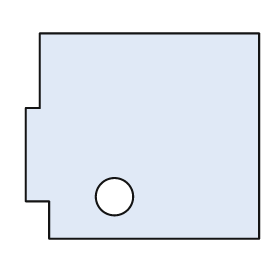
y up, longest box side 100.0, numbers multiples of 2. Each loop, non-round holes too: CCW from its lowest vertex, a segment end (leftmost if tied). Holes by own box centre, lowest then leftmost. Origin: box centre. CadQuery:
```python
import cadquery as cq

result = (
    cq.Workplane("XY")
    .moveTo(-40.0, -44.0)
    .lineTo(50.0, -44.0)
    .lineTo(50.0, 44.0)
    .lineTo(-44.0, 44.0)
    .lineTo(-44.0, 12.0)
    .lineTo(-50.0, 12.0)
    .lineTo(-50.0, -28.0)
    .lineTo(-40.0, -28.0)
    .close()
    .moveTo(-12.0, -26.0)
    .circle(8.0)
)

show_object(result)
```